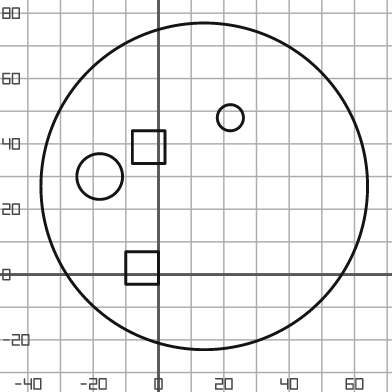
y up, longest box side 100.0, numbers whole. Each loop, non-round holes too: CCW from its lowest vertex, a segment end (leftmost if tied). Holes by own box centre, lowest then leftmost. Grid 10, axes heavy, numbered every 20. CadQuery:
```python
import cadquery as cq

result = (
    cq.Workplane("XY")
    .moveTo(14.0, 27.0)
    .circle(50.0)
    .moveTo(-10.0, -3.0)
    .lineTo(0.0, -3.0)
    .lineTo(0.0, 7.0)
    .lineTo(-10.0, 7.0)
    .close()
    .moveTo(-18.0, 30.0)
    .circle(7.0)
    .moveTo(-8.0, 34.0)
    .lineTo(2.0, 34.0)
    .lineTo(2.0, 44.0)
    .lineTo(-8.0, 44.0)
    .close()
    .moveTo(22.0, 48.0)
    .circle(4.0)
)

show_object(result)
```